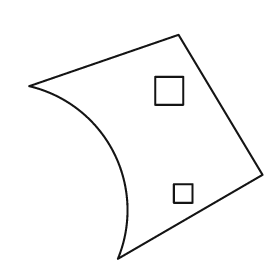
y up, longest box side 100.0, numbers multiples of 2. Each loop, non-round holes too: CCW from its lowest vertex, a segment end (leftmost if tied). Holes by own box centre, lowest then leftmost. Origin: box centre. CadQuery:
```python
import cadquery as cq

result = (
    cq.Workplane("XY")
    .moveTo(-12.0, -48.0)
    .lineTo(50.0, -12.0)
    .lineTo(14.0, 48.0)
    .lineTo(-50.0, 26.0)
    .threePointArc((-14.0, -2.0), (-12.0, -48.0))
    .close()
    .moveTo(12.0, -24.0)
    .lineTo(20.0, -24.0)
    .lineTo(20.0, -16.0)
    .lineTo(12.0, -16.0)
    .close()
    .moveTo(4.0, 18.0)
    .lineTo(16.0, 18.0)
    .lineTo(16.0, 30.0)
    .lineTo(4.0, 30.0)
    .close()
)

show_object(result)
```